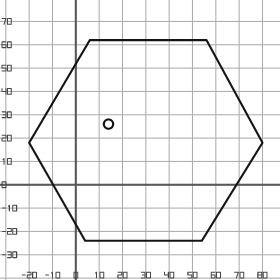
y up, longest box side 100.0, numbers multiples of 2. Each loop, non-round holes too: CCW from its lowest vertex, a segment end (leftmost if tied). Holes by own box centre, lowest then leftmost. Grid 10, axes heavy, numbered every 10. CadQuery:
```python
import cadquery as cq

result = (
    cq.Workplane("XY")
    .moveTo(4.0, -24.0)
    .lineTo(54.0, -24.0)
    .lineTo(80.0, 18.0)
    .lineTo(56.0, 62.0)
    .lineTo(6.0, 62.0)
    .lineTo(-20.0, 18.0)
    .close()
    .moveTo(14.0, 26.0)
    .circle(2.0)
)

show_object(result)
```